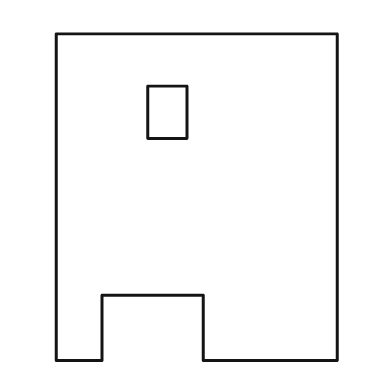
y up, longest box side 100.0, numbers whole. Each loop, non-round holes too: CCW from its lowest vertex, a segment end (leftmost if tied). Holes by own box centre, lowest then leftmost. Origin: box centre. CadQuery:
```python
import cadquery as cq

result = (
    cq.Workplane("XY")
    .moveTo(-43.0, -50.0)
    .lineTo(-29.0, -50.0)
    .lineTo(-29.0, -30.0)
    .lineTo(2.0, -30.0)
    .lineTo(2.0, -50.0)
    .lineTo(43.0, -50.0)
    .lineTo(43.0, 50.0)
    .lineTo(-43.0, 50.0)
    .close()
    .moveTo(-15.0, 18.0)
    .lineTo(-3.0, 18.0)
    .lineTo(-3.0, 34.0)
    .lineTo(-15.0, 34.0)
    .close()
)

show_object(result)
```